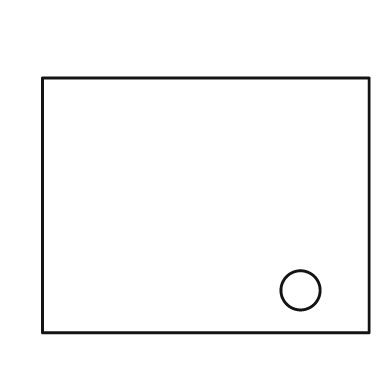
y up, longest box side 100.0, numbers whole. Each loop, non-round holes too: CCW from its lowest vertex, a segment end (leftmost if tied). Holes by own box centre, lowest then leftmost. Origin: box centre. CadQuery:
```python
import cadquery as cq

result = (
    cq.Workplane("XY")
    .moveTo(-50.0, -39.0)
    .lineTo(50.0, -39.0)
    .lineTo(50.0, 39.0)
    .lineTo(-50.0, 39.0)
    .close()
    .moveTo(29.0, -26.0)
    .circle(6.0)
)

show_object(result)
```